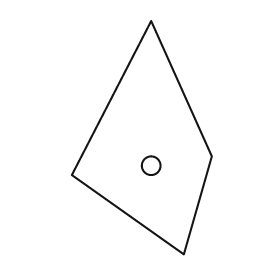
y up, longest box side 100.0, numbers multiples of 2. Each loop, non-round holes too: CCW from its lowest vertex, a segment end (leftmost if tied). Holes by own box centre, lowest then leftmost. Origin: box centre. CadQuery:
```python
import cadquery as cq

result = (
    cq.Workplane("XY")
    .moveTo(18.0, -50.0)
    .lineTo(30.0, -8.0)
    .lineTo(4.0, 50.0)
    .lineTo(-30.0, -16.0)
    .close()
    .moveTo(4.0, -12.0)
    .circle(4.0)
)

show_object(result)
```